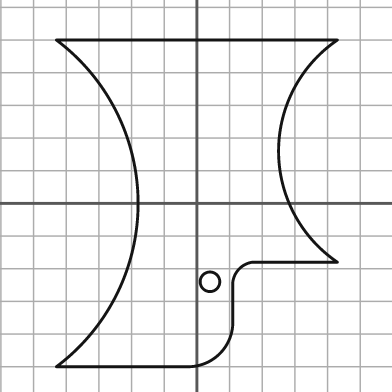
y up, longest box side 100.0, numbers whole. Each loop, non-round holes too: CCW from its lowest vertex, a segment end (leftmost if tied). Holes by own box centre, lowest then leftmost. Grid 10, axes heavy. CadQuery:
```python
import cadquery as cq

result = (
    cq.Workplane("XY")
    .moveTo(-43.0, -50.0)
    .lineTo(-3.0, -50.0)
    .threePointArc((7.0, -46.0), (11.0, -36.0))
    .lineTo(11.0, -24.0)
    .threePointArc((13.0, -20.0), (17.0, -18.0))
    .lineTo(43.0, -18.0)
    .threePointArc((25.0, 16.0), (43.0, 50.0))
    .lineTo(-43.0, 50.0)
    .threePointArc((-18.0, 0.0), (-43.0, -50.0))
    .close()
    .moveTo(4.0, -24.0)
    .circle(3.0)
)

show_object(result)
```